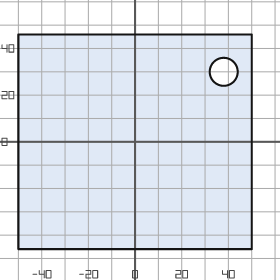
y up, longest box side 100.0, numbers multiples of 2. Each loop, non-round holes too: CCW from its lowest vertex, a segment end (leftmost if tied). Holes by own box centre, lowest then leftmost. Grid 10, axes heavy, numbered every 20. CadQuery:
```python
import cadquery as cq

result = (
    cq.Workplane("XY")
    .moveTo(-50.0, -46.0)
    .lineTo(50.0, -46.0)
    .lineTo(50.0, 46.0)
    .lineTo(-50.0, 46.0)
    .close()
    .moveTo(38.0, 30.0)
    .circle(6.0)
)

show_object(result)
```